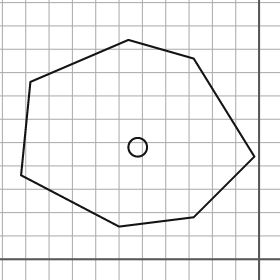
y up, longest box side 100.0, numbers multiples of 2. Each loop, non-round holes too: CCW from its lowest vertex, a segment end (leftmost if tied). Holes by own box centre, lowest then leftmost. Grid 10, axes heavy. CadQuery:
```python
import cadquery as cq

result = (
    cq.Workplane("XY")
    .moveTo(-60.0, 14.0)
    .lineTo(-28.0, 18.0)
    .lineTo(-2.0, 44.0)
    .lineTo(-28.0, 86.0)
    .lineTo(-56.0, 94.0)
    .lineTo(-98.0, 76.0)
    .lineTo(-102.0, 36.0)
    .close()
    .moveTo(-52.0, 48.0)
    .circle(4.0)
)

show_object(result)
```